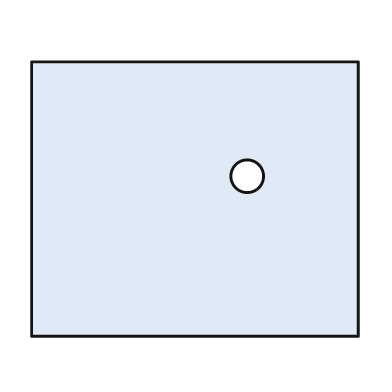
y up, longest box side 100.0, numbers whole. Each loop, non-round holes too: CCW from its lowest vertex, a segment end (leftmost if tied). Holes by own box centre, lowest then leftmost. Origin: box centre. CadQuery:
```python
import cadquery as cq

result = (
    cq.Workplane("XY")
    .moveTo(-50.0, -42.0)
    .lineTo(50.0, -42.0)
    .lineTo(50.0, 42.0)
    .lineTo(-50.0, 42.0)
    .close()
    .moveTo(16.0, 7.0)
    .circle(5.0)
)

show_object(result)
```